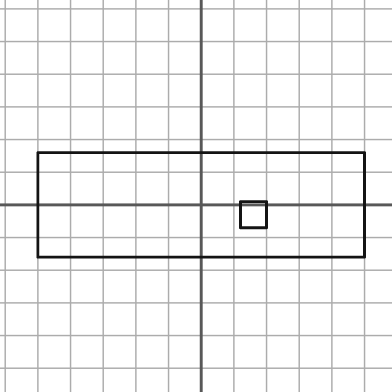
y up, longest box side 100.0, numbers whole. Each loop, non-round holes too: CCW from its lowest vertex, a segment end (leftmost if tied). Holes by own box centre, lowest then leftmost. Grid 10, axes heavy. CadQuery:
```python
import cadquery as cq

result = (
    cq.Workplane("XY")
    .moveTo(-50.0, -16.0)
    .lineTo(50.0, -16.0)
    .lineTo(50.0, 16.0)
    .lineTo(-50.0, 16.0)
    .close()
    .moveTo(12.0, -7.0)
    .lineTo(20.0, -7.0)
    .lineTo(20.0, 1.0)
    .lineTo(12.0, 1.0)
    .close()
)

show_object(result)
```